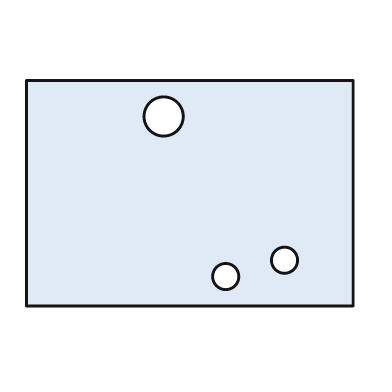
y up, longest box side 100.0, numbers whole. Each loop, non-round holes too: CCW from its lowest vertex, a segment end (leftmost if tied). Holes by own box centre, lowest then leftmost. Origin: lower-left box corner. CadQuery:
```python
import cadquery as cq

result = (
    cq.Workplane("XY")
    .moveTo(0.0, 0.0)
    .lineTo(100.0, 0.0)
    .lineTo(100.0, 69.0)
    .lineTo(0.0, 69.0)
    .close()
    .moveTo(61.0, 9.0)
    .circle(4.0)
    .moveTo(79.0, 14.0)
    .circle(4.0)
    .moveTo(42.0, 58.0)
    .circle(6.0)
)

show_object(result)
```